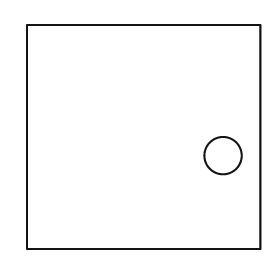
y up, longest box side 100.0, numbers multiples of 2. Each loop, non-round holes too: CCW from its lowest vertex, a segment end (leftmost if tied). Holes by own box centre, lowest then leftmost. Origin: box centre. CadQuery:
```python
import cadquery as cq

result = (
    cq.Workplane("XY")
    .moveTo(-50.0, -48.0)
    .lineTo(50.0, -48.0)
    .lineTo(50.0, 48.0)
    .lineTo(-50.0, 48.0)
    .close()
    .moveTo(34.0, -8.0)
    .circle(8.0)
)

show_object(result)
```